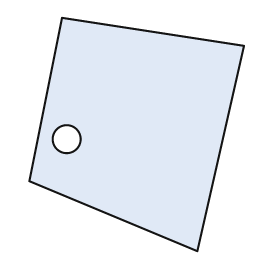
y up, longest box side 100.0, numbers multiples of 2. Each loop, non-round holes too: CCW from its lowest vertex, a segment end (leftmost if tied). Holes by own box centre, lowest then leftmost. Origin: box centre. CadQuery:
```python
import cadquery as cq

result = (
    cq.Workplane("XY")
    .moveTo(26.0, -50.0)
    .lineTo(46.0, 38.0)
    .lineTo(-32.0, 50.0)
    .lineTo(-46.0, -20.0)
    .close()
    .moveTo(-30.0, -2.0)
    .circle(6.0)
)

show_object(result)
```